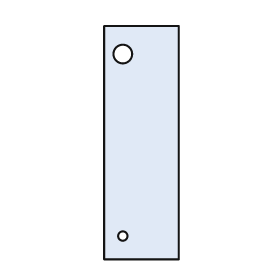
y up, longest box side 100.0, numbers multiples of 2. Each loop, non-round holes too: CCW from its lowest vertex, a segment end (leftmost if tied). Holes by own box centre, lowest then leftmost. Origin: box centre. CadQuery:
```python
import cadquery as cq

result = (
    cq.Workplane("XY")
    .moveTo(-16.0, -50.0)
    .lineTo(16.0, -50.0)
    .lineTo(16.0, 50.0)
    .lineTo(-16.0, 50.0)
    .close()
    .moveTo(-8.0, -40.0)
    .circle(2.0)
    .moveTo(-8.0, 38.0)
    .circle(4.0)
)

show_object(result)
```